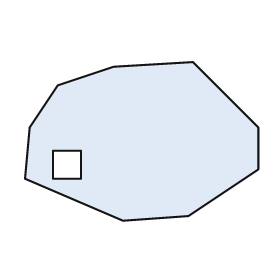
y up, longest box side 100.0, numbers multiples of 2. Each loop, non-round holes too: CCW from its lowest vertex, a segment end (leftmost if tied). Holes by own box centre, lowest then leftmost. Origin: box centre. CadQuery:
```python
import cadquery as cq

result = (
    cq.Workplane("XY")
    .moveTo(-8.0, -34.0)
    .lineTo(20.0, -32.0)
    .lineTo(50.0, -12.0)
    .lineTo(50.0, 6.0)
    .lineTo(22.0, 34.0)
    .lineTo(-12.0, 32.0)
    .lineTo(-36.0, 24.0)
    .lineTo(-48.0, 6.0)
    .lineTo(-50.0, -16.0)
    .close()
    .moveTo(-38.0, -16.0)
    .lineTo(-26.0, -16.0)
    .lineTo(-26.0, -4.0)
    .lineTo(-38.0, -4.0)
    .close()
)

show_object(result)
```